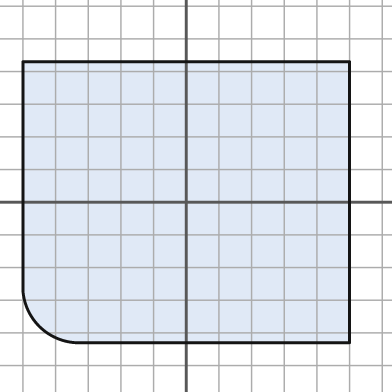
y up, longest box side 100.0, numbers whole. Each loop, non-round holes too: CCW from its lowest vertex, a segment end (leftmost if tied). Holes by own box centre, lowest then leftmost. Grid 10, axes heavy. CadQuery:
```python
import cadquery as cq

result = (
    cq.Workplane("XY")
    .moveTo(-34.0, -43.0)
    .lineTo(50.0, -43.0)
    .lineTo(50.0, 43.0)
    .lineTo(-50.0, 43.0)
    .lineTo(-50.0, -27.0)
    .threePointArc((-45.0, -38.0), (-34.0, -43.0))
    .close()
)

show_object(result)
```